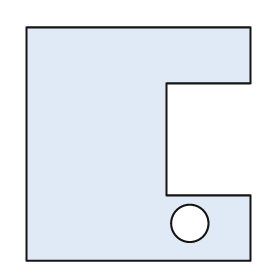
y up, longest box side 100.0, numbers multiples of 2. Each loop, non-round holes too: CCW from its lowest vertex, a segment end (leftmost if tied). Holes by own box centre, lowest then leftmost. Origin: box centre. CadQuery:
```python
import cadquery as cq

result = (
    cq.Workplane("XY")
    .moveTo(-48.0, -50.0)
    .lineTo(48.0, -50.0)
    .lineTo(48.0, -22.0)
    .lineTo(12.0, -22.0)
    .lineTo(12.0, 26.0)
    .lineTo(48.0, 26.0)
    .lineTo(48.0, 50.0)
    .lineTo(-48.0, 50.0)
    .close()
    .moveTo(22.0, -34.0)
    .circle(8.0)
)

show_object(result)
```